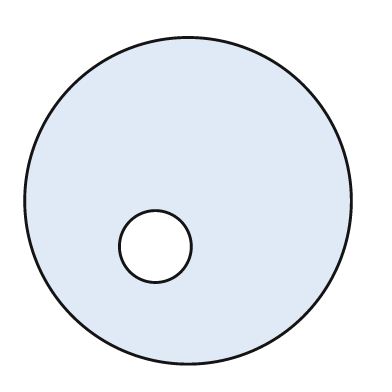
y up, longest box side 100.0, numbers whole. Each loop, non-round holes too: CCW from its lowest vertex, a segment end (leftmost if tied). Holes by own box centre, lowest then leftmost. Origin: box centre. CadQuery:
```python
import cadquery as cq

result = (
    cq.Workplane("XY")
    .moveTo(0.0, 0.0)
    .circle(50.0)
    .moveTo(-10.0, -14.0)
    .circle(11.0)
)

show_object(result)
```